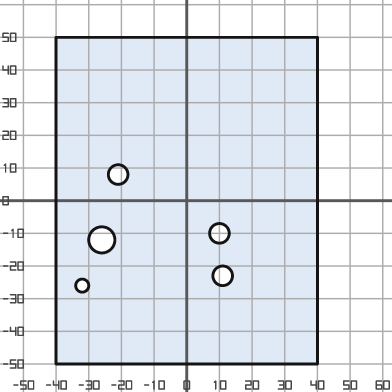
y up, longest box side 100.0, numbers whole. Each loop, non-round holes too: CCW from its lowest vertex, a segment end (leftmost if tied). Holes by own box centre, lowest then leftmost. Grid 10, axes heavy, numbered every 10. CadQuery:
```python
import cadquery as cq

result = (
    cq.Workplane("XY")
    .moveTo(-40.0, -50.0)
    .lineTo(40.0, -50.0)
    .lineTo(40.0, 50.0)
    .lineTo(-40.0, 50.0)
    .close()
    .moveTo(-32.0, -26.0)
    .circle(2.0)
    .moveTo(11.0, -23.0)
    .circle(3.0)
    .moveTo(-26.0, -12.0)
    .circle(4.0)
    .moveTo(10.0, -10.0)
    .circle(3.0)
    .moveTo(-21.0, 8.0)
    .circle(3.0)
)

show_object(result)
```